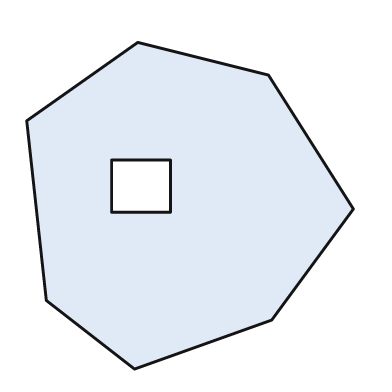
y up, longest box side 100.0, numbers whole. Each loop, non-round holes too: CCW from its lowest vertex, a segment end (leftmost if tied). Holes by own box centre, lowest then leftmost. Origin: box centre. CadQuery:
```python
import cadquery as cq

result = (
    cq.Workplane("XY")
    .moveTo(-17.0, -50.0)
    .lineTo(25.0, -35.0)
    .lineTo(50.0, -1.0)
    .lineTo(24.0, 40.0)
    .lineTo(-16.0, 50.0)
    .lineTo(-50.0, 26.0)
    .lineTo(-44.0, -29.0)
    .close()
    .moveTo(-24.0, -2.0)
    .lineTo(-6.0, -2.0)
    .lineTo(-6.0, 14.0)
    .lineTo(-24.0, 14.0)
    .close()
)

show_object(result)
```